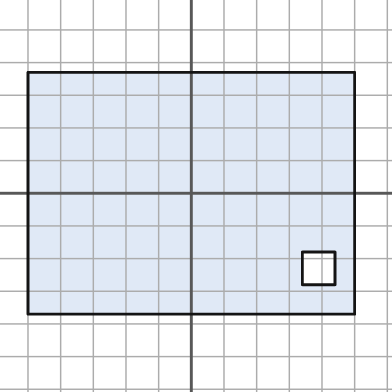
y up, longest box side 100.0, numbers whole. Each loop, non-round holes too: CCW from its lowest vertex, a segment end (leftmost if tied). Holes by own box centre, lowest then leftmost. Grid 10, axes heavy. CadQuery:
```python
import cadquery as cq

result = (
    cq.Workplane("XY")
    .moveTo(-50.0, -37.0)
    .lineTo(50.0, -37.0)
    .lineTo(50.0, 37.0)
    .lineTo(-50.0, 37.0)
    .close()
    .moveTo(34.0, -28.0)
    .lineTo(44.0, -28.0)
    .lineTo(44.0, -18.0)
    .lineTo(34.0, -18.0)
    .close()
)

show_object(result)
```